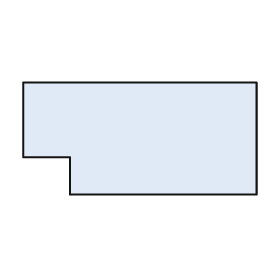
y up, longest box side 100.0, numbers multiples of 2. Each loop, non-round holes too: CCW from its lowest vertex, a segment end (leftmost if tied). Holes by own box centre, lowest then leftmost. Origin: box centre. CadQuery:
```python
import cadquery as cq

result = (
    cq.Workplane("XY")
    .moveTo(-30.0, -24.0)
    .lineTo(50.0, -24.0)
    .lineTo(50.0, 24.0)
    .lineTo(-50.0, 24.0)
    .lineTo(-50.0, -8.0)
    .lineTo(-30.0, -8.0)
    .close()
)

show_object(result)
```